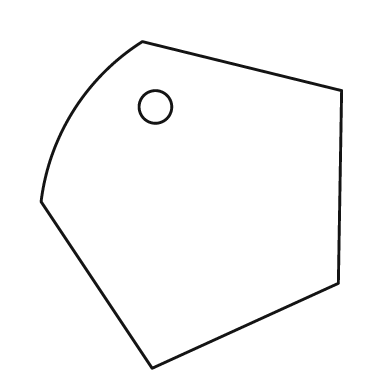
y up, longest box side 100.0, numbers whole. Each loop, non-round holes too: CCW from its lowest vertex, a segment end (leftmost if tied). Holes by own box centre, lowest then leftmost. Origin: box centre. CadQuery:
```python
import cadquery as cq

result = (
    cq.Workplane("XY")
    .moveTo(-12.0, -50.0)
    .lineTo(45.0, -24.0)
    .lineTo(46.0, 35.0)
    .lineTo(-15.0, 50.0)
    .threePointArc((-36.0, 29.0), (-46.0, 1.0))
    .close()
    .moveTo(-11.0, 30.0)
    .circle(5.0)
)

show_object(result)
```